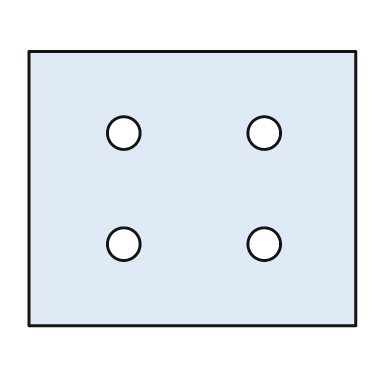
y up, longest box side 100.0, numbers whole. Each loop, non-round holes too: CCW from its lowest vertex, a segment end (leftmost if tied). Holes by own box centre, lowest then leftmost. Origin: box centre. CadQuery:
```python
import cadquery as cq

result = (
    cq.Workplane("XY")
    .moveTo(-50.0, -42.0)
    .lineTo(50.0, -42.0)
    .lineTo(50.0, 42.0)
    .lineTo(-50.0, 42.0)
    .close()
    .moveTo(-21.0, -17.0)
    .circle(5.0)
    .moveTo(22.0, -17.0)
    .circle(5.0)
    .moveTo(-21.0, 17.0)
    .circle(5.0)
    .moveTo(22.0, 17.0)
    .circle(5.0)
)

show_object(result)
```